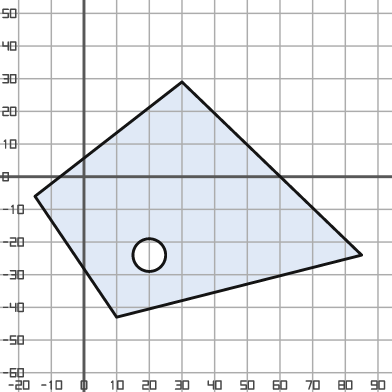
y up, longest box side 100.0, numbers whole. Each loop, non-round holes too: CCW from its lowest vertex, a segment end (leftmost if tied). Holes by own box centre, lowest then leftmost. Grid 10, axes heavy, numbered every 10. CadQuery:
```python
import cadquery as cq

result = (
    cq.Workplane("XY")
    .moveTo(10.0, -43.0)
    .lineTo(85.0, -24.0)
    .lineTo(30.0, 29.0)
    .lineTo(-15.0, -6.0)
    .close()
    .moveTo(20.0, -24.0)
    .circle(5.0)
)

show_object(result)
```